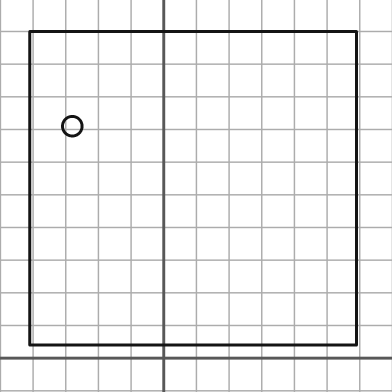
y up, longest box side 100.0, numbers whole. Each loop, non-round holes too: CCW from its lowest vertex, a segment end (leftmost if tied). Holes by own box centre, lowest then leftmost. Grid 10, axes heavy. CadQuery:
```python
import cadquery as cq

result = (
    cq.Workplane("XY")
    .moveTo(-41.0, 4.0)
    .lineTo(59.0, 4.0)
    .lineTo(59.0, 100.0)
    .lineTo(-41.0, 100.0)
    .close()
    .moveTo(-28.0, 71.0)
    .circle(3.0)
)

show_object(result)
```